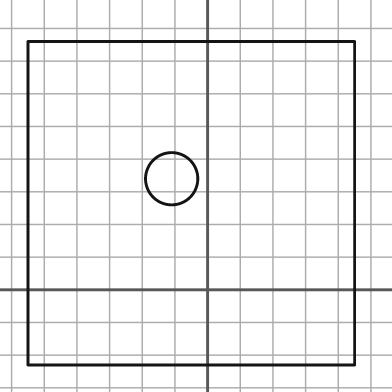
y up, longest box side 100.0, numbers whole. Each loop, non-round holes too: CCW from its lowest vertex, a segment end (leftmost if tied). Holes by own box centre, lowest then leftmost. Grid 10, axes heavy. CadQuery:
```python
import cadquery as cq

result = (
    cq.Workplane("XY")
    .moveTo(-55.0, -23.0)
    .lineTo(45.0, -23.0)
    .lineTo(45.0, 76.0)
    .lineTo(-55.0, 76.0)
    .close()
    .moveTo(-11.0, 34.0)
    .circle(8.0)
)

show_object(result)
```